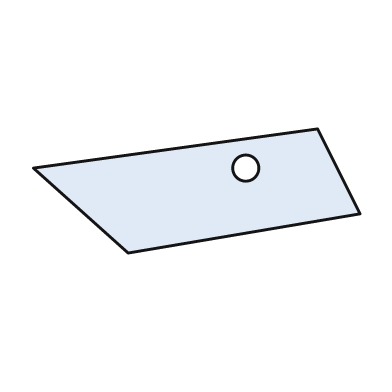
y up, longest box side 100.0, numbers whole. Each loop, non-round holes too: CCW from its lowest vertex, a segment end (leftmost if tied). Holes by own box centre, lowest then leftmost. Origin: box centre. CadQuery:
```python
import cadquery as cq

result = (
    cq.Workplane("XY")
    .moveTo(-21.0, -19.0)
    .lineTo(50.0, -7.0)
    .lineTo(37.0, 19.0)
    .lineTo(-50.0, 7.0)
    .close()
    .moveTo(15.0, 7.0)
    .circle(4.0)
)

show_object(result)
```